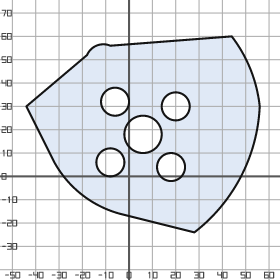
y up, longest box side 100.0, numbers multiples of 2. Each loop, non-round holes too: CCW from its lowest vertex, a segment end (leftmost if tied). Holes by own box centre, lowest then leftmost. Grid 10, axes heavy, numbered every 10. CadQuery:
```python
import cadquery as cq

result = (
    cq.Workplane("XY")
    .moveTo(28.0, -24.0)
    .threePointArc((48.0, 0.0), (56.0, 30.0))
    .threePointArc((52.0, 46.0), (44.0, 60.0))
    .lineTo(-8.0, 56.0)
    .threePointArc((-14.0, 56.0), (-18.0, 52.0))
    .lineTo(-44.0, 30.0)
    .lineTo(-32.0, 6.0)
    .threePointArc((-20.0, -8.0), (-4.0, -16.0))
    .close()
    .moveTo(18.0, 4.0)
    .circle(6.0)
    .moveTo(-8.0, 6.0)
    .circle(6.0)
    .moveTo(6.0, 18.0)
    .circle(8.0)
    .moveTo(20.0, 30.0)
    .circle(6.0)
    .moveTo(-6.0, 32.0)
    .circle(6.0)
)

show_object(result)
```